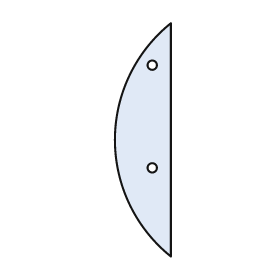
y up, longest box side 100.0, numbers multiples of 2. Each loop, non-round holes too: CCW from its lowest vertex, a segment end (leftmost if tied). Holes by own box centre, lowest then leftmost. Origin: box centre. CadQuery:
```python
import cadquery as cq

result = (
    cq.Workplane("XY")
    .moveTo(12.0, -50.0)
    .lineTo(12.0, 50.0)
    .threePointArc((-12.0, 0.0), (12.0, -50.0))
    .close()
    .moveTo(4.0, -12.0)
    .circle(2.0)
    .moveTo(4.0, 32.0)
    .circle(2.0)
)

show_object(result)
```